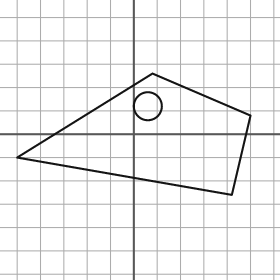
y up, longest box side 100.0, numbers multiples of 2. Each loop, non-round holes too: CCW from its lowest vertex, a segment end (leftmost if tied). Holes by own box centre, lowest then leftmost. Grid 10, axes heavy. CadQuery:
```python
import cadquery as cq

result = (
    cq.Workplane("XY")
    .moveTo(42.0, -26.0)
    .lineTo(50.0, 8.0)
    .lineTo(8.0, 26.0)
    .lineTo(-50.0, -10.0)
    .close()
    .moveTo(6.0, 12.0)
    .circle(6.0)
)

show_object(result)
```